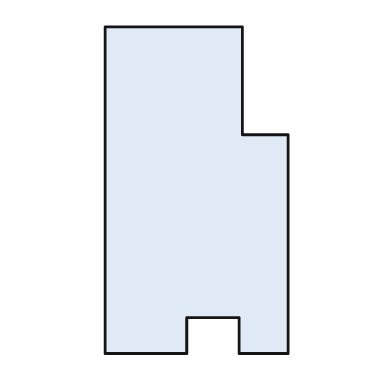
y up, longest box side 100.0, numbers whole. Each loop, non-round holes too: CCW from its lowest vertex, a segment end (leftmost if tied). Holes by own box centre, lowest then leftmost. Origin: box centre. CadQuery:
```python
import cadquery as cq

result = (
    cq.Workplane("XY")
    .moveTo(-28.0, -50.0)
    .lineTo(-3.0, -50.0)
    .lineTo(-3.0, -39.0)
    .lineTo(13.0, -39.0)
    .lineTo(13.0, -50.0)
    .lineTo(28.0, -50.0)
    .lineTo(28.0, 17.0)
    .lineTo(14.0, 17.0)
    .lineTo(14.0, 50.0)
    .lineTo(-28.0, 50.0)
    .close()
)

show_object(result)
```